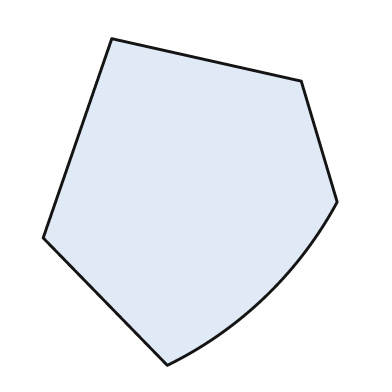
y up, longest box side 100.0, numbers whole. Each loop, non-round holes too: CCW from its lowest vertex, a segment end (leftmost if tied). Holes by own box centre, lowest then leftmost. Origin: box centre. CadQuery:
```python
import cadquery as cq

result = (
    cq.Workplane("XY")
    .moveTo(-7.0, -50.0)
    .threePointArc((23.0, -29.0), (45.0, 0.0))
    .lineTo(34.0, 37.0)
    .lineTo(-24.0, 50.0)
    .lineTo(-45.0, -11.0)
    .close()
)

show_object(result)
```